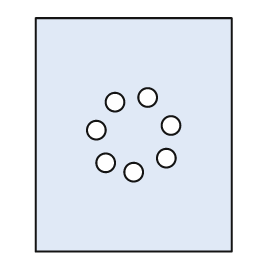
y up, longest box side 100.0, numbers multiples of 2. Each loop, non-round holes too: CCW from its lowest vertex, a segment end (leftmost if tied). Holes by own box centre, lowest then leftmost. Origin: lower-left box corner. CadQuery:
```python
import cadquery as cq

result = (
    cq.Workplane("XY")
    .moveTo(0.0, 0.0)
    .lineTo(84.0, 0.0)
    .lineTo(84.0, 100.0)
    .lineTo(0.0, 100.0)
    .close()
    .moveTo(42.0, 34.0)
    .circle(4.0)
    .moveTo(30.0, 38.0)
    .circle(4.0)
    .moveTo(56.0, 40.0)
    .circle(4.0)
    .moveTo(26.0, 52.0)
    .circle(4.0)
    .moveTo(58.0, 54.0)
    .circle(4.0)
    .moveTo(34.0, 64.0)
    .circle(4.0)
    .moveTo(48.0, 66.0)
    .circle(4.0)
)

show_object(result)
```